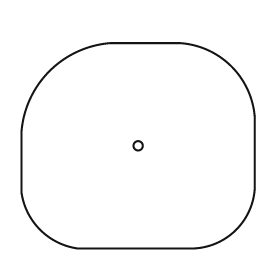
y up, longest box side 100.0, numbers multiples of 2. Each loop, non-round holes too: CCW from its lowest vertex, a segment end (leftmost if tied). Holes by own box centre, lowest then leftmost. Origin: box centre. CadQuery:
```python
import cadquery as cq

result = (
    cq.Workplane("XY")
    .moveTo(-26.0, -44.0)
    .lineTo(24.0, -44.0)
    .threePointArc((42.0, -36.0), (50.0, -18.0))
    .lineTo(50.0, 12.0)
    .threePointArc((40.0, 34.0), (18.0, 44.0))
    .lineTo(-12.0, 44.0)
    .threePointArc((-38.0, 32.0), (-50.0, 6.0))
    .lineTo(-50.0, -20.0)
    .threePointArc((-42.0, -36.0), (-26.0, -44.0))
    .close()
    .moveTo(0.0, 0.0)
    .circle(2.0)
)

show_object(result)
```